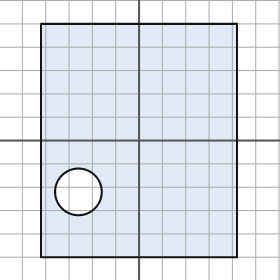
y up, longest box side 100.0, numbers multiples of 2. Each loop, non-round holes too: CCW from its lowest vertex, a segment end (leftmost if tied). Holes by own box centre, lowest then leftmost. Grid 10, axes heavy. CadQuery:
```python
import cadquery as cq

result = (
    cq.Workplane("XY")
    .moveTo(-42.0, -50.0)
    .lineTo(42.0, -50.0)
    .lineTo(42.0, 50.0)
    .lineTo(-42.0, 50.0)
    .close()
    .moveTo(-26.0, -22.0)
    .circle(10.0)
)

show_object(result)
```